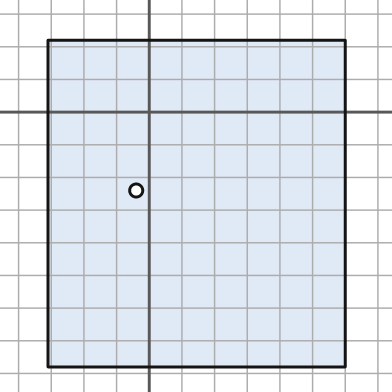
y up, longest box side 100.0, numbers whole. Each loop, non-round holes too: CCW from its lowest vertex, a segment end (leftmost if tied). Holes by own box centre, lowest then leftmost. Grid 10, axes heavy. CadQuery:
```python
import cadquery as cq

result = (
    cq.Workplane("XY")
    .moveTo(-31.0, -78.0)
    .lineTo(60.0, -78.0)
    .lineTo(60.0, 22.0)
    .lineTo(-31.0, 22.0)
    .close()
    .moveTo(-4.0, -24.0)
    .circle(2.0)
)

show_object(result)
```